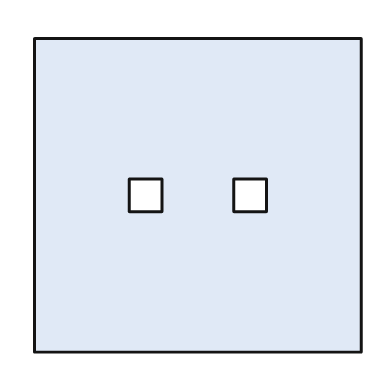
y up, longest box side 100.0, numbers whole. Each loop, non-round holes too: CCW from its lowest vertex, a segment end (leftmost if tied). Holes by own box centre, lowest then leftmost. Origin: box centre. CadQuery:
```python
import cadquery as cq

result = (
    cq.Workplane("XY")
    .moveTo(-50.0, -48.0)
    .lineTo(50.0, -48.0)
    .lineTo(50.0, 48.0)
    .lineTo(-50.0, 48.0)
    .close()
    .moveTo(-21.0, -5.0)
    .lineTo(-11.0, -5.0)
    .lineTo(-11.0, 5.0)
    .lineTo(-21.0, 5.0)
    .close()
    .moveTo(11.0, -5.0)
    .lineTo(21.0, -5.0)
    .lineTo(21.0, 5.0)
    .lineTo(11.0, 5.0)
    .close()
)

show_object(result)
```